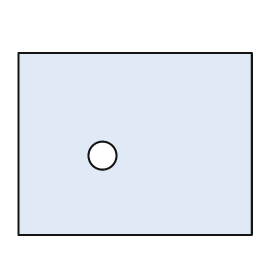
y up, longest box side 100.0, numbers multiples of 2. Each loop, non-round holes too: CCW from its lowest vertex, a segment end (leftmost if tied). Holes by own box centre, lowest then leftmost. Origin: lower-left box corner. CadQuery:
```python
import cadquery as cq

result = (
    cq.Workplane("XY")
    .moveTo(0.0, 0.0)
    .lineTo(100.0, 0.0)
    .lineTo(100.0, 78.0)
    .lineTo(0.0, 78.0)
    .close()
    .moveTo(36.0, 34.0)
    .circle(6.0)
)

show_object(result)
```